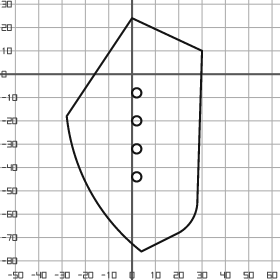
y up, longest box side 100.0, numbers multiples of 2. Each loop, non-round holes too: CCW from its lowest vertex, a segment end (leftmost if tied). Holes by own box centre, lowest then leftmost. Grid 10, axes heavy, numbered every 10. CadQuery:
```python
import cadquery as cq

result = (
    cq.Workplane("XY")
    .moveTo(4.0, -76.0)
    .lineTo(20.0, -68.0)
    .threePointArc((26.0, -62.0), (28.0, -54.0))
    .lineTo(30.0, 10.0)
    .lineTo(0.0, 24.0)
    .lineTo(-28.0, -18.0)
    .threePointArc((-18.0, -50.0), (4.0, -76.0))
    .close()
    .moveTo(2.0, -44.0)
    .circle(2.0)
    .moveTo(2.0, -32.0)
    .circle(2.0)
    .moveTo(2.0, -20.0)
    .circle(2.0)
    .moveTo(2.0, -8.0)
    .circle(2.0)
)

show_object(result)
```